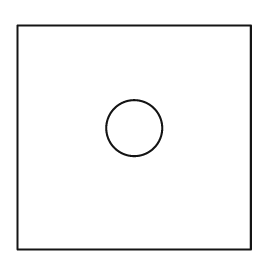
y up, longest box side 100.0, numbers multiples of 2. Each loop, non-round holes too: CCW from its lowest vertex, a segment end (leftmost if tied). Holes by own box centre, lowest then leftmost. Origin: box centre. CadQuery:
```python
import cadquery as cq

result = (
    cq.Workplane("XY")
    .moveTo(-50.0, -48.0)
    .lineTo(50.0, -48.0)
    .lineTo(50.0, 48.0)
    .lineTo(-50.0, 48.0)
    .close()
    .moveTo(0.0, 4.0)
    .circle(12.0)
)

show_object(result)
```